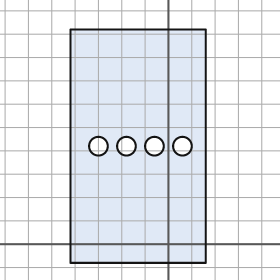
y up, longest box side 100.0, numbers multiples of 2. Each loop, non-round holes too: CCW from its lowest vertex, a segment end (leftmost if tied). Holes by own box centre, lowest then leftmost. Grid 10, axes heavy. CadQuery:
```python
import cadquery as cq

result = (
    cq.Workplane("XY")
    .moveTo(-42.0, -8.0)
    .lineTo(16.0, -8.0)
    .lineTo(16.0, 92.0)
    .lineTo(-42.0, 92.0)
    .close()
    .moveTo(-30.0, 42.0)
    .circle(4.0)
    .moveTo(-18.0, 42.0)
    .circle(4.0)
    .moveTo(-6.0, 42.0)
    .circle(4.0)
    .moveTo(6.0, 42.0)
    .circle(4.0)
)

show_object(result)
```